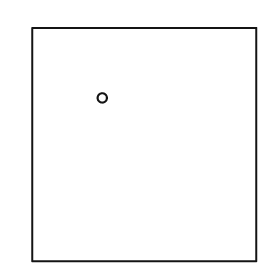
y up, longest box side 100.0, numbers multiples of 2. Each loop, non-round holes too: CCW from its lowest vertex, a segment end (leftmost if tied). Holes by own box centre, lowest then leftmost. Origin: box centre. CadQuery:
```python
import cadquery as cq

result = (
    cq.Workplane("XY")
    .moveTo(-48.0, -50.0)
    .lineTo(48.0, -50.0)
    .lineTo(48.0, 50.0)
    .lineTo(-48.0, 50.0)
    .close()
    .moveTo(-18.0, 20.0)
    .circle(2.0)
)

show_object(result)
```